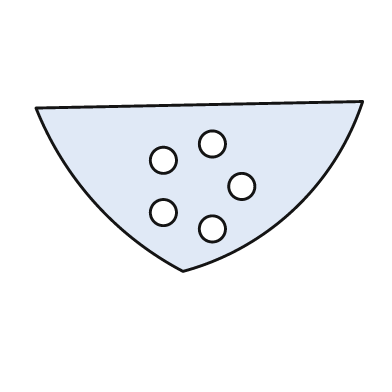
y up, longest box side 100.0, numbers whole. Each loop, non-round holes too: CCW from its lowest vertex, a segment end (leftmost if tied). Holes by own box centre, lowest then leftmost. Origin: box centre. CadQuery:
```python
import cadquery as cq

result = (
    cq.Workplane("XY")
    .moveTo(-5.0, -26.0)
    .threePointArc((29.0, -7.0), (50.0, 26.0))
    .lineTo(-50.0, 24.0)
    .threePointArc((-32.0, -5.0), (-5.0, -26.0))
    .close()
    .moveTo(4.0, -13.0)
    .circle(4.0)
    .moveTo(-11.0, -8.0)
    .circle(4.0)
    .moveTo(13.0, 0.0)
    .circle(4.0)
    .moveTo(-11.0, 8.0)
    .circle(4.0)
    .moveTo(4.0, 13.0)
    .circle(4.0)
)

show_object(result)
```